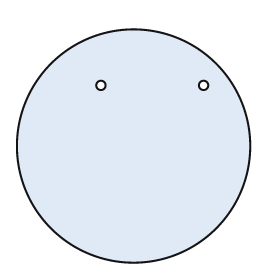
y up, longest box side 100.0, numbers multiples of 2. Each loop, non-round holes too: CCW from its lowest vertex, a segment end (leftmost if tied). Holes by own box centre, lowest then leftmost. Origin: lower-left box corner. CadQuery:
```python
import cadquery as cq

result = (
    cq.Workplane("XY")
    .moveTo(50.0, 50.0)
    .circle(50.0)
    .moveTo(36.0, 76.0)
    .circle(2.0)
    .moveTo(80.0, 76.0)
    .circle(2.0)
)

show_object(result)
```